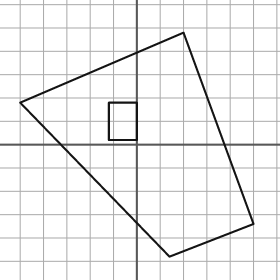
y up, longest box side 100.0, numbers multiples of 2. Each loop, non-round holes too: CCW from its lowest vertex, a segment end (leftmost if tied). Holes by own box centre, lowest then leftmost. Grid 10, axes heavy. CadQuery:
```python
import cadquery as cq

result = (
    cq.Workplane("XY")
    .moveTo(14.0, -48.0)
    .lineTo(50.0, -34.0)
    .lineTo(20.0, 48.0)
    .lineTo(-50.0, 18.0)
    .close()
    .moveTo(-12.0, 2.0)
    .lineTo(0.0, 2.0)
    .lineTo(0.0, 18.0)
    .lineTo(-12.0, 18.0)
    .close()
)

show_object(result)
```